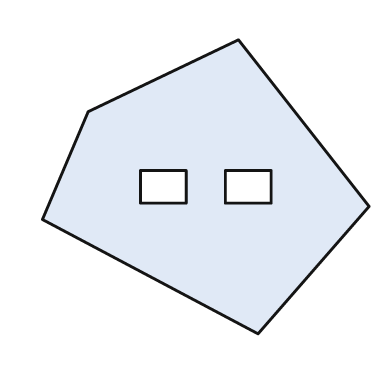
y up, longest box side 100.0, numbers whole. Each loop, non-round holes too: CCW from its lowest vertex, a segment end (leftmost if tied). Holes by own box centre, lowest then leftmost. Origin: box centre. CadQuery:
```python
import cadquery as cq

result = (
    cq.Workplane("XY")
    .moveTo(16.0, -45.0)
    .lineTo(50.0, -6.0)
    .lineTo(10.0, 45.0)
    .lineTo(-36.0, 23.0)
    .lineTo(-50.0, -10.0)
    .close()
    .moveTo(-20.0, -5.0)
    .lineTo(-6.0, -5.0)
    .lineTo(-6.0, 5.0)
    .lineTo(-20.0, 5.0)
    .close()
    .moveTo(6.0, -5.0)
    .lineTo(20.0, -5.0)
    .lineTo(20.0, 5.0)
    .lineTo(6.0, 5.0)
    .close()
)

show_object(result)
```